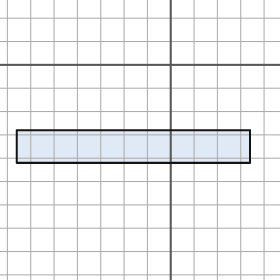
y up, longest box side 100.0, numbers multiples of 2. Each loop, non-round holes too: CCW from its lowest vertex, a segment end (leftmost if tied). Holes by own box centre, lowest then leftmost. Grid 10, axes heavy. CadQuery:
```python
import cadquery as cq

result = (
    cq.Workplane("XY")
    .moveTo(-66.0, -42.0)
    .lineTo(34.0, -42.0)
    .lineTo(34.0, -28.0)
    .lineTo(-66.0, -28.0)
    .close()
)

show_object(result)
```